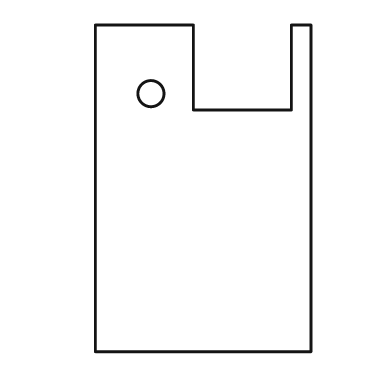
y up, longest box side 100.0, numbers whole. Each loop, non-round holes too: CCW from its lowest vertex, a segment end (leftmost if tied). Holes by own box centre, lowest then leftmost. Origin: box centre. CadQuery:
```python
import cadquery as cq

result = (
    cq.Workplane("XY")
    .moveTo(-33.0, -50.0)
    .lineTo(33.0, -50.0)
    .lineTo(33.0, 50.0)
    .lineTo(27.0, 50.0)
    .lineTo(27.0, 24.0)
    .lineTo(-3.0, 24.0)
    .lineTo(-3.0, 50.0)
    .lineTo(-33.0, 50.0)
    .close()
    .moveTo(-16.0, 29.0)
    .circle(4.0)
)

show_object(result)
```